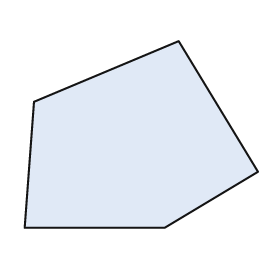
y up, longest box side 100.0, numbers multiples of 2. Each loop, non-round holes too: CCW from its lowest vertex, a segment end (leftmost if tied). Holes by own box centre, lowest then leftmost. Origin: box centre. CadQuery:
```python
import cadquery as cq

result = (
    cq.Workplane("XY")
    .moveTo(-50.0, -40.0)
    .lineTo(10.0, -40.0)
    .lineTo(50.0, -16.0)
    .lineTo(16.0, 40.0)
    .lineTo(-46.0, 14.0)
    .close()
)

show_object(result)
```